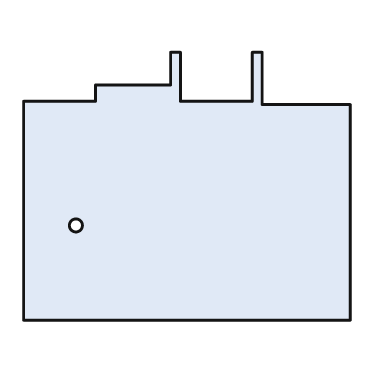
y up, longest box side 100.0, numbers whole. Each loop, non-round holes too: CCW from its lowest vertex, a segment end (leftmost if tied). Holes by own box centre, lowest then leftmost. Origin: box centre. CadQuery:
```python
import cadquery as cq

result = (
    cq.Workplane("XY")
    .moveTo(-50.0, -41.0)
    .lineTo(50.0, -41.0)
    .lineTo(50.0, 25.0)
    .lineTo(23.0, 25.0)
    .lineTo(23.0, 41.0)
    .lineTo(20.0, 41.0)
    .lineTo(20.0, 26.0)
    .lineTo(-2.0, 26.0)
    .lineTo(-2.0, 41.0)
    .lineTo(-5.0, 41.0)
    .lineTo(-5.0, 31.0)
    .lineTo(-28.0, 31.0)
    .lineTo(-28.0, 26.0)
    .lineTo(-50.0, 26.0)
    .close()
    .moveTo(-34.0, -12.0)
    .circle(2.0)
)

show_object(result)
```